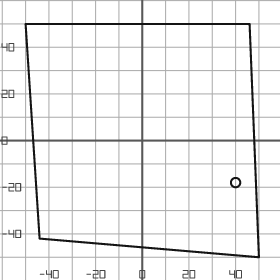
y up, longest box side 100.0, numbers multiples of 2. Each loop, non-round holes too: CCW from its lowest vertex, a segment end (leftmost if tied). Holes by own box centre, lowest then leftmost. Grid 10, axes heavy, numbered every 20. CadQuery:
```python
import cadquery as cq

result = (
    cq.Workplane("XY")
    .moveTo(50.0, -50.0)
    .lineTo(46.0, 50.0)
    .lineTo(-50.0, 50.0)
    .lineTo(-44.0, -42.0)
    .close()
    .moveTo(40.0, -18.0)
    .circle(2.0)
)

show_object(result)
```